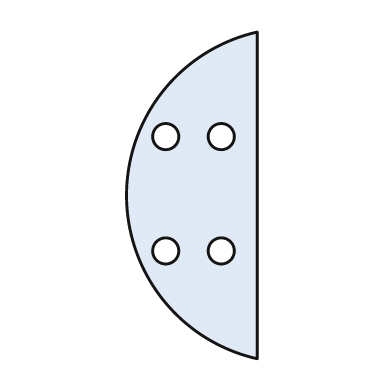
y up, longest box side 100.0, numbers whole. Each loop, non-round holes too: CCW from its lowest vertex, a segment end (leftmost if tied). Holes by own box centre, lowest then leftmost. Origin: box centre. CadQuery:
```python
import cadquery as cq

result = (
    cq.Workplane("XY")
    .moveTo(20.0, -50.0)
    .lineTo(20.0, 50.0)
    .threePointArc((-20.0, 0.0), (20.0, -50.0))
    .close()
    .moveTo(-8.0, -17.0)
    .circle(4.0)
    .moveTo(9.0, -17.0)
    .circle(4.0)
    .moveTo(-8.0, 18.0)
    .circle(4.0)
    .moveTo(9.0, 18.0)
    .circle(4.0)
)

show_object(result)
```